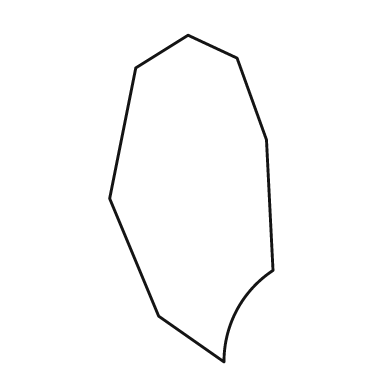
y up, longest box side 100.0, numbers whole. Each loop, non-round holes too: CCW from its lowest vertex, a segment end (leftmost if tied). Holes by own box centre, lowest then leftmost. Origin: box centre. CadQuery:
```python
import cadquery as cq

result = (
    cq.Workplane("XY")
    .moveTo(10.0, -50.0)
    .threePointArc((14.0, -34.0), (25.0, -22.0))
    .lineTo(23.0, 18.0)
    .lineTo(14.0, 43.0)
    .lineTo(-1.0, 50.0)
    .lineTo(-17.0, 40.0)
    .lineTo(-25.0, 0.0)
    .lineTo(-10.0, -36.0)
    .close()
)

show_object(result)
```